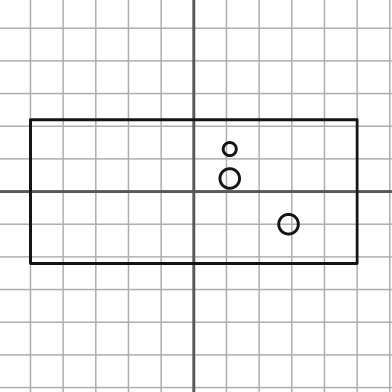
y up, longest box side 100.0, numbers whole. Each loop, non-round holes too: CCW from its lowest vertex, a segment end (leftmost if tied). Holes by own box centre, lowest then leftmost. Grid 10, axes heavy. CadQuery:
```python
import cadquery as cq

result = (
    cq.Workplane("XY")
    .moveTo(-50.0, -22.0)
    .lineTo(50.0, -22.0)
    .lineTo(50.0, 22.0)
    .lineTo(-50.0, 22.0)
    .close()
    .moveTo(29.0, -10.0)
    .circle(3.0)
    .moveTo(11.0, 4.0)
    .circle(3.0)
    .moveTo(11.0, 13.0)
    .circle(2.0)
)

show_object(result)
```